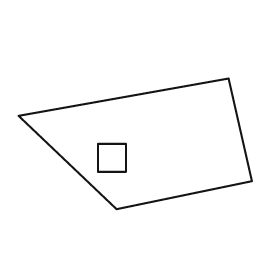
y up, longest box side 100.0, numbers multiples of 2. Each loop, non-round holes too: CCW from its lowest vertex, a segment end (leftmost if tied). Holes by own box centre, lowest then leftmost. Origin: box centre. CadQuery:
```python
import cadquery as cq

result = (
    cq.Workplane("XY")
    .moveTo(-8.0, -28.0)
    .lineTo(50.0, -16.0)
    .lineTo(40.0, 28.0)
    .lineTo(-50.0, 12.0)
    .close()
    .moveTo(-16.0, -12.0)
    .lineTo(-4.0, -12.0)
    .lineTo(-4.0, 0.0)
    .lineTo(-16.0, 0.0)
    .close()
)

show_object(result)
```